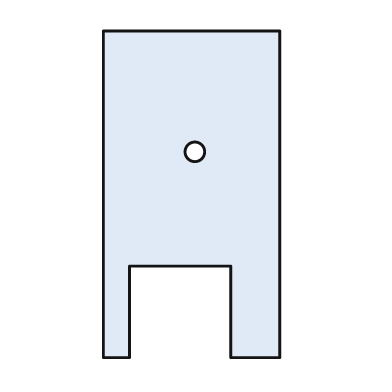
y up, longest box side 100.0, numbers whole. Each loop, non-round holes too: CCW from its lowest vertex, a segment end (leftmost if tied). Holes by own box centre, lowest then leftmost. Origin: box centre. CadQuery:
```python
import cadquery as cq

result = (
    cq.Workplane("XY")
    .moveTo(-27.0, -50.0)
    .lineTo(-19.0, -50.0)
    .lineTo(-19.0, -22.0)
    .lineTo(12.0, -22.0)
    .lineTo(12.0, -50.0)
    .lineTo(27.0, -50.0)
    .lineTo(27.0, 50.0)
    .lineTo(-27.0, 50.0)
    .close()
    .moveTo(1.0, 13.0)
    .circle(3.0)
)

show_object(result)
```